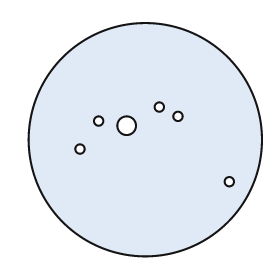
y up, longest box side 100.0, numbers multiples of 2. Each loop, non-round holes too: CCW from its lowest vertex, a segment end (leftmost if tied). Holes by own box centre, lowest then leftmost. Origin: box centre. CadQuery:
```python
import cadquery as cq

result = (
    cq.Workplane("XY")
    .moveTo(0.0, 0.0)
    .circle(50.0)
    .moveTo(36.0, -18.0)
    .circle(2.0)
    .moveTo(-28.0, -4.0)
    .circle(2.0)
    .moveTo(-8.0, 6.0)
    .circle(4.0)
    .moveTo(-20.0, 8.0)
    .circle(2.0)
    .moveTo(14.0, 10.0)
    .circle(2.0)
    .moveTo(6.0, 14.0)
    .circle(2.0)
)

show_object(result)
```